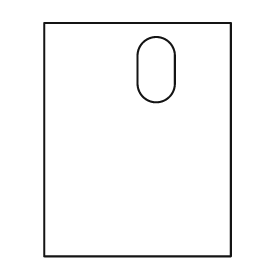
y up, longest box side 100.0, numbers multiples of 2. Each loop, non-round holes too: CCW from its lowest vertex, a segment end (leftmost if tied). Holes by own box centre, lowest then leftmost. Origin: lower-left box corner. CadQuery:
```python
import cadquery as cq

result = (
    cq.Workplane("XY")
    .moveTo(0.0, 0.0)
    .lineTo(80.0, 0.0)
    .lineTo(80.0, 100.0)
    .lineTo(0.0, 100.0)
    .close()
    .moveTo(40.0, 74.0)
    .threePointArc((48.0, 66.0), (56.0, 74.0))
    .lineTo(56.0, 86.0)
    .threePointArc((48.0, 94.0), (40.0, 86.0))
    .close()
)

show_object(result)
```